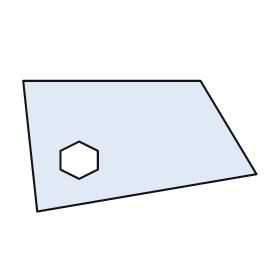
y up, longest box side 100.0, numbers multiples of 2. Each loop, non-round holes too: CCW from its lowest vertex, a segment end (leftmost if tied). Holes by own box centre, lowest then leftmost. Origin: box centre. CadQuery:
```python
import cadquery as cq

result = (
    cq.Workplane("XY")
    .moveTo(-44.0, -28.0)
    .lineTo(50.0, -12.0)
    .lineTo(26.0, 28.0)
    .lineTo(-50.0, 28.0)
    .close()
    .moveTo(-26.0, -14.0)
    .lineTo(-18.0, -10.0)
    .lineTo(-18.0, -2.0)
    .lineTo(-26.0, 2.0)
    .lineTo(-34.0, -2.0)
    .lineTo(-34.0, -10.0)
    .close()
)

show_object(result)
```